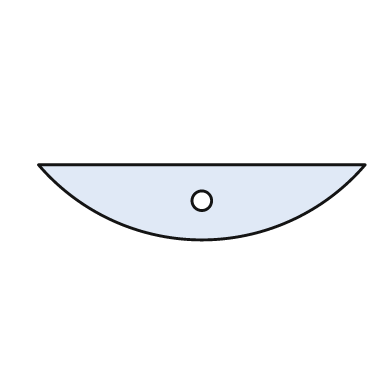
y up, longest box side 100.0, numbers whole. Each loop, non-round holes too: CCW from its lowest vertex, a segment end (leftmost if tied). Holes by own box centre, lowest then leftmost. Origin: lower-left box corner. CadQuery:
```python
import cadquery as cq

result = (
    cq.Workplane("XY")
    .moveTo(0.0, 23.0)
    .threePointArc((50.0, 0.0), (100.0, 23.0))
    .close()
    .moveTo(50.0, 12.0)
    .circle(3.0)
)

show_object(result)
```